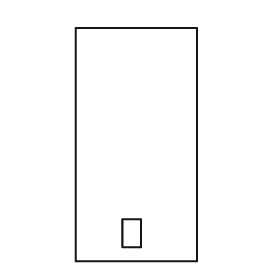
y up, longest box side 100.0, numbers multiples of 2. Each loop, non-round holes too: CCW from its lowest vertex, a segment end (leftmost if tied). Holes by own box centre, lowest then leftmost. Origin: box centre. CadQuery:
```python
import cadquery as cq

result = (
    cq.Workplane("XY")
    .moveTo(-26.0, -50.0)
    .lineTo(26.0, -50.0)
    .lineTo(26.0, 50.0)
    .lineTo(-26.0, 50.0)
    .close()
    .moveTo(-6.0, -44.0)
    .lineTo(2.0, -44.0)
    .lineTo(2.0, -32.0)
    .lineTo(-6.0, -32.0)
    .close()
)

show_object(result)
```